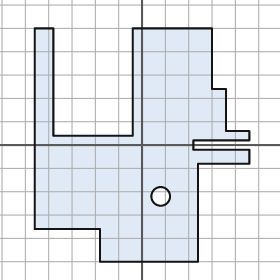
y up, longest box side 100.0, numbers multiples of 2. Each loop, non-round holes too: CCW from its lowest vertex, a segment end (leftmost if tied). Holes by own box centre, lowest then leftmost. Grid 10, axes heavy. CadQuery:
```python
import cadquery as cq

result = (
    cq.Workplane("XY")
    .moveTo(-18.0, -50.0)
    .lineTo(24.0, -50.0)
    .lineTo(24.0, -8.0)
    .lineTo(46.0, -8.0)
    .lineTo(46.0, -2.0)
    .lineTo(22.0, -2.0)
    .lineTo(22.0, 2.0)
    .lineTo(46.0, 2.0)
    .lineTo(46.0, 6.0)
    .lineTo(36.0, 6.0)
    .lineTo(36.0, 24.0)
    .lineTo(30.0, 24.0)
    .lineTo(30.0, 50.0)
    .lineTo(-4.0, 50.0)
    .lineTo(-4.0, 4.0)
    .lineTo(-38.0, 4.0)
    .lineTo(-38.0, 50.0)
    .lineTo(-46.0, 50.0)
    .lineTo(-46.0, -36.0)
    .lineTo(-18.0, -36.0)
    .close()
    .moveTo(8.0, -22.0)
    .circle(4.0)
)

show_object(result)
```